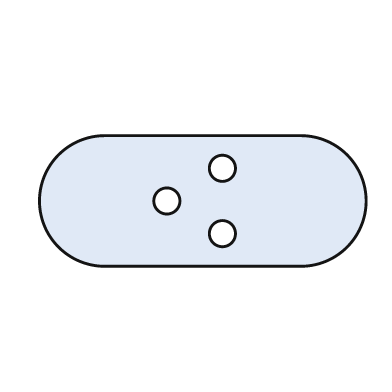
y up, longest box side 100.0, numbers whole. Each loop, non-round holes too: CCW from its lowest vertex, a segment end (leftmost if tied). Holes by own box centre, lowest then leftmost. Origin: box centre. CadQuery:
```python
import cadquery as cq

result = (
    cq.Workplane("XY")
    .moveTo(-30.0, -20.0)
    .lineTo(30.0, -20.0)
    .threePointArc((50.0, 0.0), (30.0, 20.0))
    .lineTo(-30.0, 20.0)
    .threePointArc((-50.0, 0.0), (-30.0, -20.0))
    .close()
    .moveTo(6.0, -10.0)
    .circle(4.0)
    .moveTo(-11.0, 0.0)
    .circle(4.0)
    .moveTo(6.0, 10.0)
    .circle(4.0)
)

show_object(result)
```